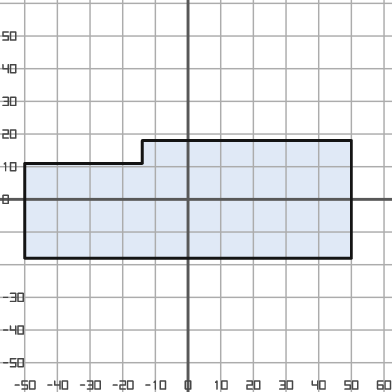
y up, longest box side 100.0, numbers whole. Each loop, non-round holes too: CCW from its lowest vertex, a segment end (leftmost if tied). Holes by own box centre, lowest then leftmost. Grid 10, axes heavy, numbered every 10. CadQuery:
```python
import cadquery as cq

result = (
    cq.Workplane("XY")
    .moveTo(-50.0, -18.0)
    .lineTo(50.0, -18.0)
    .lineTo(50.0, 18.0)
    .lineTo(-14.0, 18.0)
    .lineTo(-14.0, 11.0)
    .lineTo(-50.0, 11.0)
    .close()
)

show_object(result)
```